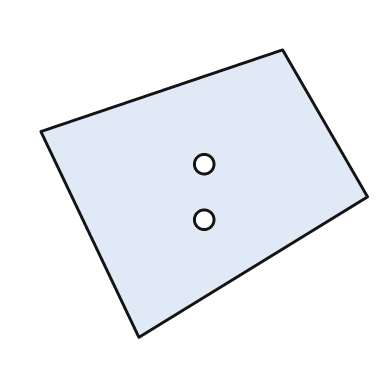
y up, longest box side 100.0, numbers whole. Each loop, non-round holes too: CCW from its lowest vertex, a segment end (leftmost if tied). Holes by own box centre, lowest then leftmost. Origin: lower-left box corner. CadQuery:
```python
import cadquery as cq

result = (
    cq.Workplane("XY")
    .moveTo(30.0, 0.0)
    .lineTo(100.0, 43.0)
    .lineTo(74.0, 88.0)
    .lineTo(0.0, 63.0)
    .close()
    .moveTo(50.0, 36.0)
    .circle(3.0)
    .moveTo(50.0, 53.0)
    .circle(3.0)
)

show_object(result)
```